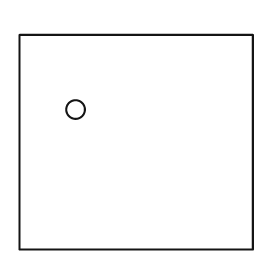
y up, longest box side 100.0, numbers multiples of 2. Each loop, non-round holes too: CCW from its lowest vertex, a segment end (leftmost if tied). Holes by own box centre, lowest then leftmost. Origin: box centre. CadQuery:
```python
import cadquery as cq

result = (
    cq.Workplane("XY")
    .moveTo(-50.0, -46.0)
    .lineTo(50.0, -46.0)
    .lineTo(50.0, 46.0)
    .lineTo(-50.0, 46.0)
    .close()
    .moveTo(-26.0, 14.0)
    .circle(4.0)
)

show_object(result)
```